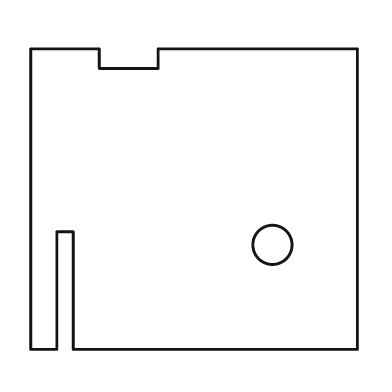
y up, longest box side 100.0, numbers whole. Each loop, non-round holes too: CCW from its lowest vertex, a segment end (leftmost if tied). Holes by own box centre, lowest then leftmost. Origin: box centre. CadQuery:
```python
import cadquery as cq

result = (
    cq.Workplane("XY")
    .moveTo(-50.0, -46.0)
    .lineTo(-42.0, -46.0)
    .lineTo(-42.0, -10.0)
    .lineTo(-37.0, -10.0)
    .lineTo(-37.0, -46.0)
    .lineTo(50.0, -46.0)
    .lineTo(50.0, 46.0)
    .lineTo(-11.0, 46.0)
    .lineTo(-11.0, 40.0)
    .lineTo(-29.0, 40.0)
    .lineTo(-29.0, 46.0)
    .lineTo(-50.0, 46.0)
    .close()
    .moveTo(24.0, -14.0)
    .circle(6.0)
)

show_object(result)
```